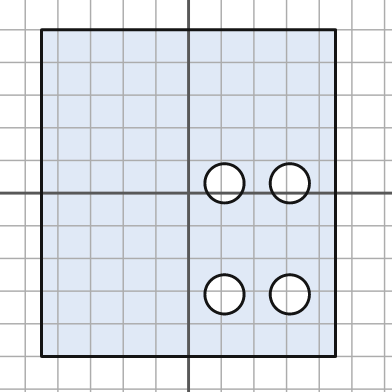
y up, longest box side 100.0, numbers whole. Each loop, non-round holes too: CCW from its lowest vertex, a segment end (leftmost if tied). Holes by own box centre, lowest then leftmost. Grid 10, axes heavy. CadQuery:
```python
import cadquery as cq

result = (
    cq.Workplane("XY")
    .moveTo(-45.0, -50.0)
    .lineTo(45.0, -50.0)
    .lineTo(45.0, 50.0)
    .lineTo(-45.0, 50.0)
    .close()
    .moveTo(11.0, -31.0)
    .circle(6.0)
    .moveTo(31.0, -31.0)
    .circle(6.0)
    .moveTo(11.0, 3.0)
    .circle(6.0)
    .moveTo(31.0, 3.0)
    .circle(6.0)
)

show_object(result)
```